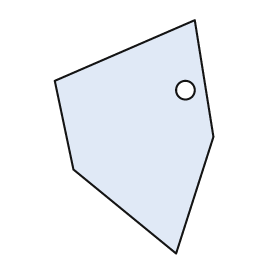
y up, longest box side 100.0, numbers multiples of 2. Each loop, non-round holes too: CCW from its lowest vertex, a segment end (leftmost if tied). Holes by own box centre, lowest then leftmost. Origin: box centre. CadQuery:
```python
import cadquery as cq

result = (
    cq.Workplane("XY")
    .moveTo(18.0, -50.0)
    .lineTo(34.0, 0.0)
    .lineTo(26.0, 50.0)
    .lineTo(-34.0, 24.0)
    .lineTo(-26.0, -14.0)
    .close()
    .moveTo(22.0, 20.0)
    .circle(4.0)
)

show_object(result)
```